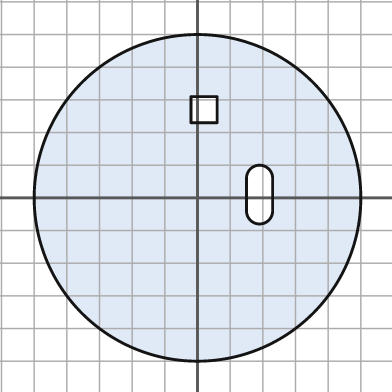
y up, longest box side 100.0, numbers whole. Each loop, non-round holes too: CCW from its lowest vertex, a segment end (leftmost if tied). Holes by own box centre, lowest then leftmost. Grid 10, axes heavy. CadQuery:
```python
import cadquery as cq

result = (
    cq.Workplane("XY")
    .moveTo(0.0, 0.0)
    .circle(50.0)
    .moveTo(15.0, -4.0)
    .threePointArc((19.0, -8.0), (23.0, -4.0))
    .lineTo(23.0, 6.0)
    .threePointArc((19.0, 10.0), (15.0, 6.0))
    .close()
    .moveTo(-2.0, 23.0)
    .lineTo(6.0, 23.0)
    .lineTo(6.0, 31.0)
    .lineTo(-2.0, 31.0)
    .close()
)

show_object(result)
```